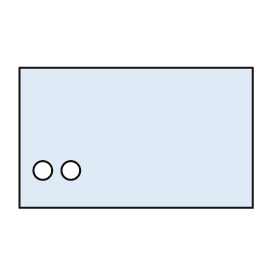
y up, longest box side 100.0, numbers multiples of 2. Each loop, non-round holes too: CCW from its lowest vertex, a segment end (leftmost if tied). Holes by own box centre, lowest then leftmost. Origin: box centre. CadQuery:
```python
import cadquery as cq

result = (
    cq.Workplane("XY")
    .moveTo(-50.0, -30.0)
    .lineTo(50.0, -30.0)
    .lineTo(50.0, 30.0)
    .lineTo(-50.0, 30.0)
    .close()
    .moveTo(-40.0, -14.0)
    .circle(4.0)
    .moveTo(-28.0, -14.0)
    .circle(4.0)
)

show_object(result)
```